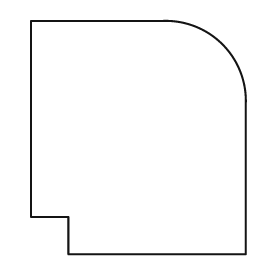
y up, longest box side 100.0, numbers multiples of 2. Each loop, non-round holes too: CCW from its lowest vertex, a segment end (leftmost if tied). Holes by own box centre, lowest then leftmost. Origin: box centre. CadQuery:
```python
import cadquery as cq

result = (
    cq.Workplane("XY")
    .moveTo(-30.0, -50.0)
    .lineTo(46.0, -50.0)
    .lineTo(46.0, 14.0)
    .threePointArc((36.0, 40.0), (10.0, 50.0))
    .lineTo(-46.0, 50.0)
    .lineTo(-46.0, -34.0)
    .lineTo(-30.0, -34.0)
    .close()
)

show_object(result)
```